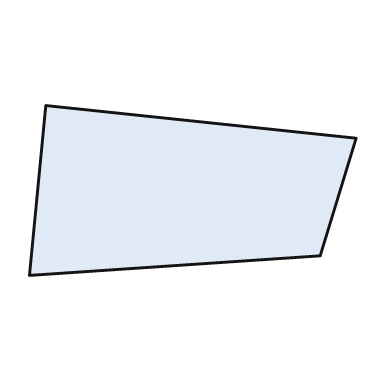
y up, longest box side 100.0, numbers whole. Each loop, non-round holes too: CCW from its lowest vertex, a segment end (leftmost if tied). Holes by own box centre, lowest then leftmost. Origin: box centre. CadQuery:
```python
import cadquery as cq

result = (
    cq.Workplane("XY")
    .moveTo(-50.0, -26.0)
    .lineTo(39.0, -20.0)
    .lineTo(50.0, 16.0)
    .lineTo(-45.0, 26.0)
    .close()
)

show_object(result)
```